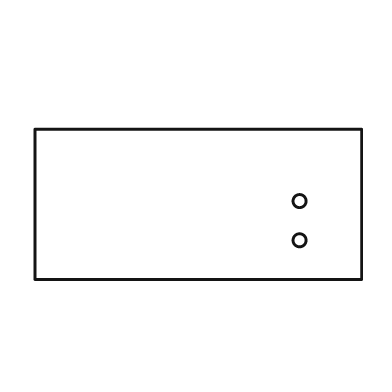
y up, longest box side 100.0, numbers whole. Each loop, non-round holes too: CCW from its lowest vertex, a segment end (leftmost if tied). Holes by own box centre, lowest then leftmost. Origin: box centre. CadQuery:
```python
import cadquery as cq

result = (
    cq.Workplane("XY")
    .moveTo(-50.0, -23.0)
    .lineTo(50.0, -23.0)
    .lineTo(50.0, 23.0)
    .lineTo(-50.0, 23.0)
    .close()
    .moveTo(31.0, -11.0)
    .circle(2.0)
    .moveTo(31.0, 1.0)
    .circle(2.0)
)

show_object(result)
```